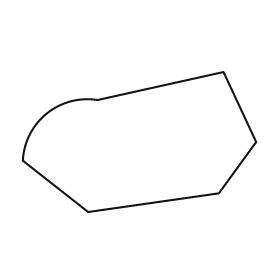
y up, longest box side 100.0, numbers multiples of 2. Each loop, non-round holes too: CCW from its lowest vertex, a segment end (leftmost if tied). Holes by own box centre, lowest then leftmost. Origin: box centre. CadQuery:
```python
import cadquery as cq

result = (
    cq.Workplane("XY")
    .moveTo(-22.0, -30.0)
    .lineTo(34.0, -22.0)
    .lineTo(50.0, 0.0)
    .lineTo(36.0, 30.0)
    .lineTo(-18.0, 18.0)
    .threePointArc((-40.0, 12.0), (-50.0, -8.0))
    .close()
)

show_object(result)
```